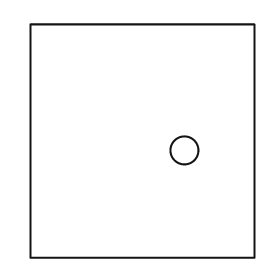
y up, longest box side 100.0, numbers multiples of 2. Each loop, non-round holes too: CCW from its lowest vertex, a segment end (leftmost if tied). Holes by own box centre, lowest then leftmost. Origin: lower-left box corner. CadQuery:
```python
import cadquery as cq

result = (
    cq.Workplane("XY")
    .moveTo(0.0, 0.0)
    .lineTo(96.0, 0.0)
    .lineTo(96.0, 100.0)
    .lineTo(0.0, 100.0)
    .close()
    .moveTo(66.0, 46.0)
    .circle(6.0)
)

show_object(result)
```